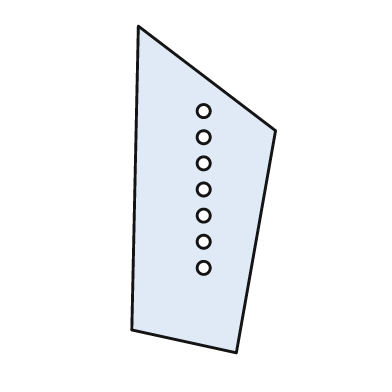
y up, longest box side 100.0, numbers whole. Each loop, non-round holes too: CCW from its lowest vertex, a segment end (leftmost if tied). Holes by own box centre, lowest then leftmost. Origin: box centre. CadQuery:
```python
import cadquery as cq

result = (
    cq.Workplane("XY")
    .moveTo(10.0, -50.0)
    .lineTo(22.0, 18.0)
    .lineTo(-20.0, 50.0)
    .lineTo(-22.0, -43.0)
    .close()
    .moveTo(0.0, -24.0)
    .circle(2.0)
    .moveTo(0.0, -16.0)
    .circle(2.0)
    .moveTo(0.0, -8.0)
    .circle(2.0)
    .moveTo(0.0, 0.0)
    .circle(2.0)
    .moveTo(0.0, 8.0)
    .circle(2.0)
    .moveTo(0.0, 16.0)
    .circle(2.0)
    .moveTo(0.0, 24.0)
    .circle(2.0)
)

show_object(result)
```